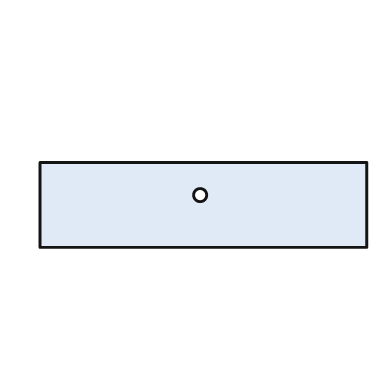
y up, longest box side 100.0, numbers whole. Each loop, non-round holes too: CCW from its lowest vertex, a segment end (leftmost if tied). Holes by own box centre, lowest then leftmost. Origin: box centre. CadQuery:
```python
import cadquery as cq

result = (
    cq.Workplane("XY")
    .moveTo(-50.0, -13.0)
    .lineTo(50.0, -13.0)
    .lineTo(50.0, 13.0)
    .lineTo(-50.0, 13.0)
    .close()
    .moveTo(-1.0, 3.0)
    .circle(2.0)
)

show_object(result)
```